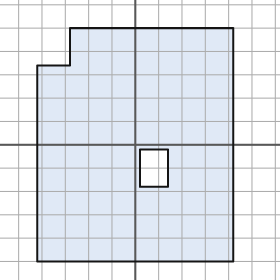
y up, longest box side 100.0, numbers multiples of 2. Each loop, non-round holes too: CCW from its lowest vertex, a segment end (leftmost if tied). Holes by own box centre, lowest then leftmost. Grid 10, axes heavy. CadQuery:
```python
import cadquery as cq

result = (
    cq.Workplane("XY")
    .moveTo(-42.0, -50.0)
    .lineTo(42.0, -50.0)
    .lineTo(42.0, 50.0)
    .lineTo(-28.0, 50.0)
    .lineTo(-28.0, 34.0)
    .lineTo(-42.0, 34.0)
    .close()
    .moveTo(2.0, -18.0)
    .lineTo(14.0, -18.0)
    .lineTo(14.0, -2.0)
    .lineTo(2.0, -2.0)
    .close()
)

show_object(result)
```